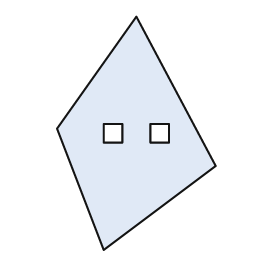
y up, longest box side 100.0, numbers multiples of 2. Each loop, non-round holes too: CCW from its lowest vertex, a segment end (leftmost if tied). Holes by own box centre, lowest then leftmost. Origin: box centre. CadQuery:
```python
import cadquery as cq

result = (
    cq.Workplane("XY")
    .moveTo(-14.0, -50.0)
    .lineTo(34.0, -14.0)
    .lineTo(0.0, 50.0)
    .lineTo(-34.0, 2.0)
    .close()
    .moveTo(-14.0, -4.0)
    .lineTo(-6.0, -4.0)
    .lineTo(-6.0, 4.0)
    .lineTo(-14.0, 4.0)
    .close()
    .moveTo(6.0, -4.0)
    .lineTo(14.0, -4.0)
    .lineTo(14.0, 4.0)
    .lineTo(6.0, 4.0)
    .close()
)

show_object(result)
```